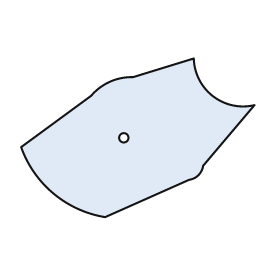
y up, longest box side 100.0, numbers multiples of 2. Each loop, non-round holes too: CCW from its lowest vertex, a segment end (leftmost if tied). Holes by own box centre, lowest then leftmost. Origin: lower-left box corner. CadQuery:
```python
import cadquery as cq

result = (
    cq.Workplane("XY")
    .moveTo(36.0, 0.0)
    .lineTo(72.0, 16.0)
    .threePointArc((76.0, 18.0), (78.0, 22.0))
    .lineTo(100.0, 48.0)
    .threePointArc((82.0, 52.0), (74.0, 68.0))
    .lineTo(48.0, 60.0)
    .threePointArc((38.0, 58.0), (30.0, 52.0))
    .lineTo(0.0, 30.0)
    .threePointArc((14.0, 10.0), (36.0, 0.0))
    .close()
    .moveTo(44.0, 34.0)
    .circle(2.0)
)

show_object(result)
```